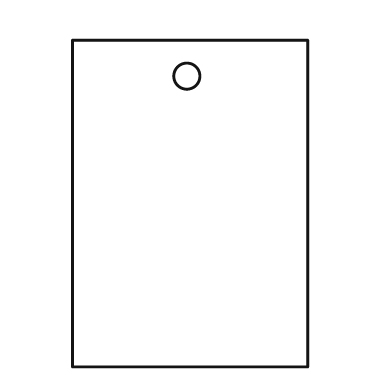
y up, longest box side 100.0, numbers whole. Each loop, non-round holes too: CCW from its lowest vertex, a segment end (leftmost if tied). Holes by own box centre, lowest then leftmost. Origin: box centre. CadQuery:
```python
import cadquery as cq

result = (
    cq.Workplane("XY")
    .moveTo(-36.0, -50.0)
    .lineTo(36.0, -50.0)
    .lineTo(36.0, 50.0)
    .lineTo(-36.0, 50.0)
    .close()
    .moveTo(-1.0, 39.0)
    .circle(4.0)
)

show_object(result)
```